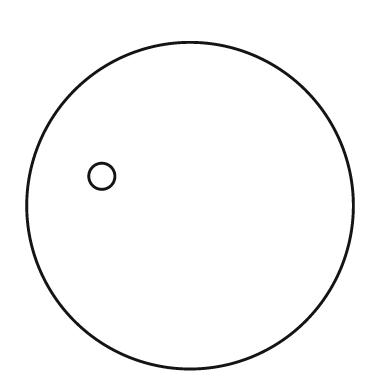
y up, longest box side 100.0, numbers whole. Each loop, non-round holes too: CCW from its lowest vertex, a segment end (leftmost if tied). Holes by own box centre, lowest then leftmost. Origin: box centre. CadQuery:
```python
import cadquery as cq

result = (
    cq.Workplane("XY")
    .moveTo(0.0, 0.0)
    .circle(50.0)
    .moveTo(-27.0, 9.0)
    .circle(4.0)
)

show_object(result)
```